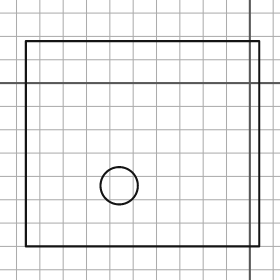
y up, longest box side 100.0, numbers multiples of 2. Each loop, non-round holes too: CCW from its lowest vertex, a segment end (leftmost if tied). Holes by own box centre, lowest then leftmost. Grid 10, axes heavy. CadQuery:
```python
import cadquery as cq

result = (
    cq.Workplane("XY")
    .moveTo(-96.0, -70.0)
    .lineTo(4.0, -70.0)
    .lineTo(4.0, 18.0)
    .lineTo(-96.0, 18.0)
    .close()
    .moveTo(-56.0, -44.0)
    .circle(8.0)
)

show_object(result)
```